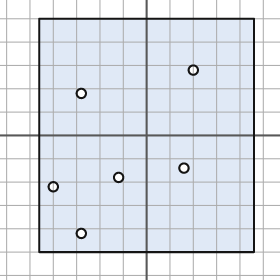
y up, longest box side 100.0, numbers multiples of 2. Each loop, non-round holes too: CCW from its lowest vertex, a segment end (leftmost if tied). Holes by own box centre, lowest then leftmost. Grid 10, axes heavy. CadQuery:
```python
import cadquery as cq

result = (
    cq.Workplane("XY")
    .moveTo(-46.0, -50.0)
    .lineTo(46.0, -50.0)
    .lineTo(46.0, 50.0)
    .lineTo(-46.0, 50.0)
    .close()
    .moveTo(-28.0, -42.0)
    .circle(2.0)
    .moveTo(-40.0, -22.0)
    .circle(2.0)
    .moveTo(-12.0, -18.0)
    .circle(2.0)
    .moveTo(16.0, -14.0)
    .circle(2.0)
    .moveTo(-28.0, 18.0)
    .circle(2.0)
    .moveTo(20.0, 28.0)
    .circle(2.0)
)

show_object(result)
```